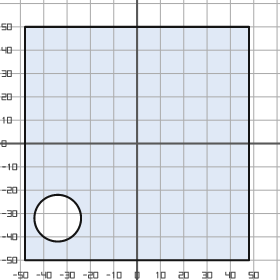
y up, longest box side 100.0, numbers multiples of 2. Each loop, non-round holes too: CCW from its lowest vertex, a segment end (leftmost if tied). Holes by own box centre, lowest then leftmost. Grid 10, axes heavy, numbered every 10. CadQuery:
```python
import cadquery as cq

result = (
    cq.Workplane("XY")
    .moveTo(-48.0, -50.0)
    .lineTo(48.0, -50.0)
    .lineTo(48.0, 50.0)
    .lineTo(-48.0, 50.0)
    .close()
    .moveTo(-34.0, -32.0)
    .circle(10.0)
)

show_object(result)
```